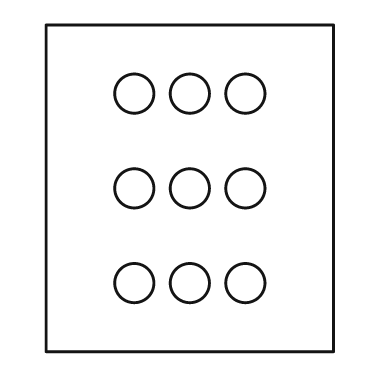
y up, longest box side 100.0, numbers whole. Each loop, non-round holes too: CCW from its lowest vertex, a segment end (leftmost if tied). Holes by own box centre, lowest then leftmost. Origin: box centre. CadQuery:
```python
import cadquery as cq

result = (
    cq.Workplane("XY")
    .moveTo(-44.0, -50.0)
    .lineTo(44.0, -50.0)
    .lineTo(44.0, 50.0)
    .lineTo(-44.0, 50.0)
    .close()
    .moveTo(-17.0, -29.0)
    .circle(6.0)
    .moveTo(0.0, -29.0)
    .circle(6.0)
    .moveTo(17.0, -29.0)
    .circle(6.0)
    .moveTo(-17.0, 0.0)
    .circle(6.0)
    .moveTo(0.0, 0.0)
    .circle(6.0)
    .moveTo(17.0, 0.0)
    .circle(6.0)
    .moveTo(-17.0, 29.0)
    .circle(6.0)
    .moveTo(0.0, 29.0)
    .circle(6.0)
    .moveTo(17.0, 29.0)
    .circle(6.0)
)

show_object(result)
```